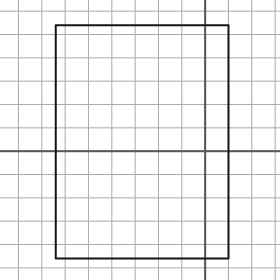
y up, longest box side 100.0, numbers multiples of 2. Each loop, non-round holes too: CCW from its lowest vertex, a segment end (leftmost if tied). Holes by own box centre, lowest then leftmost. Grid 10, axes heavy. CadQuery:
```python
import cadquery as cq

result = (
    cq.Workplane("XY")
    .moveTo(-64.0, -46.0)
    .lineTo(10.0, -46.0)
    .lineTo(10.0, 54.0)
    .lineTo(-64.0, 54.0)
    .close()
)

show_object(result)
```